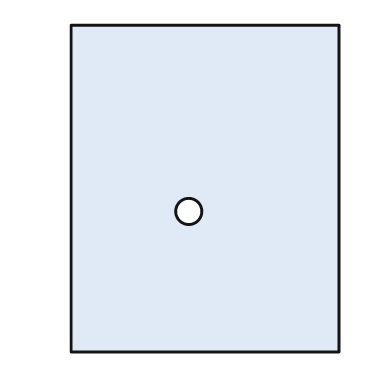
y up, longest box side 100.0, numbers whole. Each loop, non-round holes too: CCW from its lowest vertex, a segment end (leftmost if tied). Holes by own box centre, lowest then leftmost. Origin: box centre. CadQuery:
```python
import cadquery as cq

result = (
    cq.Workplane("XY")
    .moveTo(-41.0, -50.0)
    .lineTo(41.0, -50.0)
    .lineTo(41.0, 50.0)
    .lineTo(-41.0, 50.0)
    .close()
    .moveTo(-5.0, -7.0)
    .circle(4.0)
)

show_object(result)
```